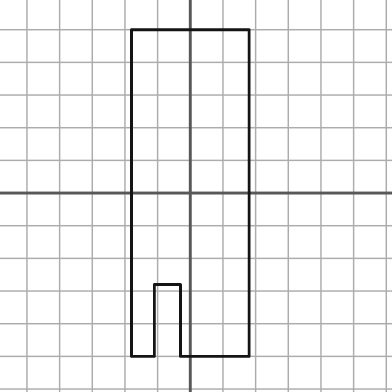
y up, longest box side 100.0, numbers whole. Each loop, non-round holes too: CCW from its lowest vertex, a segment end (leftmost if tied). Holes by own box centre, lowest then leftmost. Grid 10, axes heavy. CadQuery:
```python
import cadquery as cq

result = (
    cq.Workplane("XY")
    .moveTo(-18.0, -50.0)
    .lineTo(-11.0, -50.0)
    .lineTo(-11.0, -28.0)
    .lineTo(-3.0, -28.0)
    .lineTo(-3.0, -50.0)
    .lineTo(18.0, -50.0)
    .lineTo(18.0, 50.0)
    .lineTo(-18.0, 50.0)
    .close()
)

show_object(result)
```